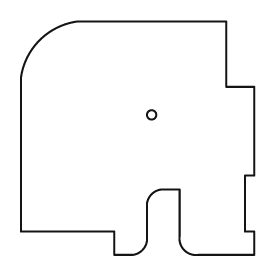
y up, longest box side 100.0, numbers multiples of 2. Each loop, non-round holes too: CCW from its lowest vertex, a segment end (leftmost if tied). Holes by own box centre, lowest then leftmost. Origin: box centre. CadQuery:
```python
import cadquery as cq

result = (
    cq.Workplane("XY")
    .moveTo(-10.0, -50.0)
    .lineTo(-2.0, -50.0)
    .threePointArc((2.0, -48.0), (4.0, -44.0))
    .lineTo(4.0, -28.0)
    .threePointArc((6.0, -24.0), (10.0, -22.0))
    .lineTo(18.0, -22.0)
    .lineTo(18.0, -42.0)
    .threePointArc((20.0, -48.0), (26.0, -50.0))
    .lineTo(50.0, -50.0)
    .lineTo(50.0, -40.0)
    .lineTo(46.0, -40.0)
    .lineTo(46.0, -16.0)
    .lineTo(50.0, -16.0)
    .lineTo(50.0, 22.0)
    .lineTo(38.0, 22.0)
    .lineTo(38.0, 50.0)
    .lineTo(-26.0, 50.0)
    .threePointArc((-42.0, 42.0), (-50.0, 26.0))
    .lineTo(-50.0, -40.0)
    .lineTo(-10.0, -40.0)
    .close()
    .moveTo(6.0, 10.0)
    .circle(2.0)
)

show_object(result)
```